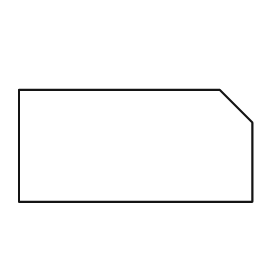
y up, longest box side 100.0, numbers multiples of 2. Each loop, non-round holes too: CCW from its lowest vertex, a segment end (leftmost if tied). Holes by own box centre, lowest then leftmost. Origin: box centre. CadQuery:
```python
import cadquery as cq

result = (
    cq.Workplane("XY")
    .moveTo(-50.0, -24.0)
    .lineTo(50.0, -24.0)
    .lineTo(50.0, 10.0)
    .lineTo(36.0, 24.0)
    .lineTo(-50.0, 24.0)
    .close()
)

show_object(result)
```